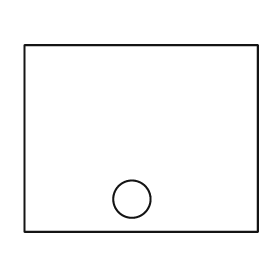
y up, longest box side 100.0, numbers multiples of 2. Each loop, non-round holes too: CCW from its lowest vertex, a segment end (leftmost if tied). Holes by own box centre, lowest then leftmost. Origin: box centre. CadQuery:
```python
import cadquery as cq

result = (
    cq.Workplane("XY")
    .moveTo(-50.0, -40.0)
    .lineTo(50.0, -40.0)
    .lineTo(50.0, 40.0)
    .lineTo(-50.0, 40.0)
    .close()
    .moveTo(-4.0, -26.0)
    .circle(8.0)
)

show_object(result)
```